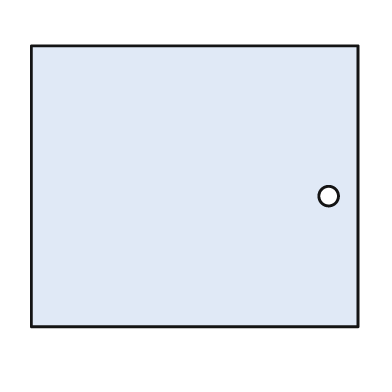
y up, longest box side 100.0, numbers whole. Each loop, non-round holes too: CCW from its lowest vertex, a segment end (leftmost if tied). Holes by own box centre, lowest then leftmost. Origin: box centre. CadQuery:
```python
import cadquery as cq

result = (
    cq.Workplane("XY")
    .moveTo(-50.0, -43.0)
    .lineTo(50.0, -43.0)
    .lineTo(50.0, 43.0)
    .lineTo(-50.0, 43.0)
    .close()
    .moveTo(41.0, -3.0)
    .circle(3.0)
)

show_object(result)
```